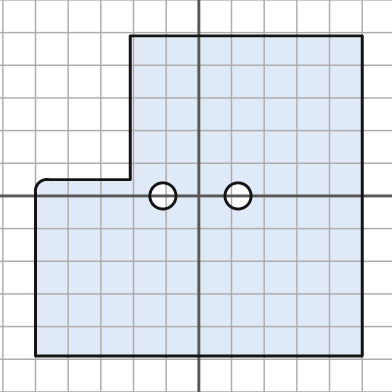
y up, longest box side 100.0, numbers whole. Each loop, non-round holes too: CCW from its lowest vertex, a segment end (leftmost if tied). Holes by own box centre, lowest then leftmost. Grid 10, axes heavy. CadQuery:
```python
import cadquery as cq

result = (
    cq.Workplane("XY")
    .moveTo(-50.0, -49.0)
    .lineTo(50.0, -49.0)
    .lineTo(50.0, 49.0)
    .lineTo(-21.0, 49.0)
    .lineTo(-21.0, 5.0)
    .lineTo(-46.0, 5.0)
    .threePointArc((-49.0, 4.0), (-50.0, 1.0))
    .close()
    .moveTo(-11.0, 0.0)
    .circle(4.0)
    .moveTo(12.0, 0.0)
    .circle(4.0)
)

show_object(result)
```